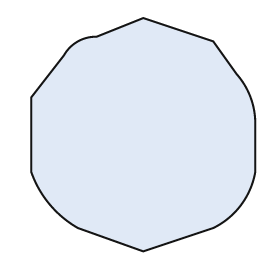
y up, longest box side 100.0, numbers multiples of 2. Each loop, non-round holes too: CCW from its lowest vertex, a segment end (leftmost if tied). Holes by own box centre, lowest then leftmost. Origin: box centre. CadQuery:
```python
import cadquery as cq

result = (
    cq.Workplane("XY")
    .moveTo(0.0, -50.0)
    .lineTo(30.0, -40.0)
    .threePointArc((42.0, -30.0), (48.0, -16.0))
    .lineTo(48.0, 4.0)
    .threePointArc((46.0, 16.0), (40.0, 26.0))
    .lineTo(30.0, 40.0)
    .lineTo(0.0, 50.0)
    .lineTo(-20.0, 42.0)
    .threePointArc((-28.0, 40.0), (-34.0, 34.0))
    .lineTo(-48.0, 16.0)
    .lineTo(-48.0, -16.0)
    .threePointArc((-40.0, -30.0), (-28.0, -40.0))
    .close()
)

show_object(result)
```